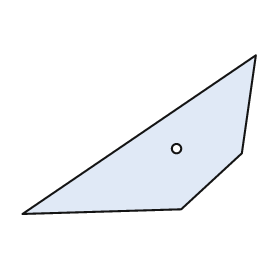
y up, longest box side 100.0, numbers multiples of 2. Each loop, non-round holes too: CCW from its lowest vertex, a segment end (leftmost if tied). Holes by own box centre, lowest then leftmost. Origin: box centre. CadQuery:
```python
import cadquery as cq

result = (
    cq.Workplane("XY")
    .moveTo(-50.0, -34.0)
    .lineTo(18.0, -32.0)
    .lineTo(44.0, -8.0)
    .lineTo(50.0, 34.0)
    .close()
    .moveTo(16.0, -6.0)
    .circle(2.0)
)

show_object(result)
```